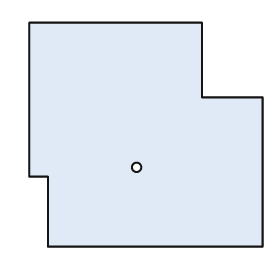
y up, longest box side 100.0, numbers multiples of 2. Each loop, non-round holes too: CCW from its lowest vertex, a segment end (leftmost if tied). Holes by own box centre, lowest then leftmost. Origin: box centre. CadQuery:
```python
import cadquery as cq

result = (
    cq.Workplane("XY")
    .moveTo(-42.0, -48.0)
    .lineTo(50.0, -48.0)
    .lineTo(50.0, 16.0)
    .lineTo(24.0, 16.0)
    .lineTo(24.0, 48.0)
    .lineTo(-50.0, 48.0)
    .lineTo(-50.0, -18.0)
    .lineTo(-42.0, -18.0)
    .close()
    .moveTo(-4.0, -14.0)
    .circle(2.0)
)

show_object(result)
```